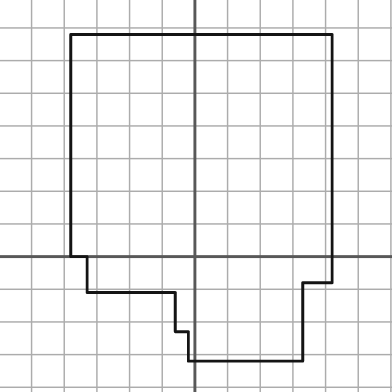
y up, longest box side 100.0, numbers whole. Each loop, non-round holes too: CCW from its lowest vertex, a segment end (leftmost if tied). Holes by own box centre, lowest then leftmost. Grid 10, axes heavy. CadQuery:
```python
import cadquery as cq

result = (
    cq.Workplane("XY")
    .moveTo(-2.0, -32.0)
    .lineTo(33.0, -32.0)
    .lineTo(33.0, -8.0)
    .lineTo(42.0, -8.0)
    .lineTo(42.0, 68.0)
    .lineTo(-38.0, 68.0)
    .lineTo(-38.0, 0.0)
    .lineTo(-33.0, 0.0)
    .lineTo(-33.0, -11.0)
    .lineTo(-6.0, -11.0)
    .lineTo(-6.0, -23.0)
    .lineTo(-2.0, -23.0)
    .close()
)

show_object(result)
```